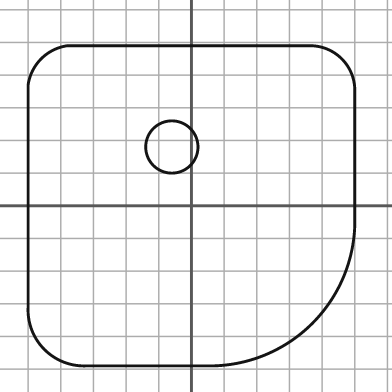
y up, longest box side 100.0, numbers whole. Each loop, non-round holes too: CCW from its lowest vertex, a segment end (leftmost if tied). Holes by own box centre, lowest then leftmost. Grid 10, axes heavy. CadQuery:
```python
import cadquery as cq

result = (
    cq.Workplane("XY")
    .moveTo(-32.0, -49.0)
    .lineTo(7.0, -49.0)
    .threePointArc((37.0, -36.0), (50.0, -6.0))
    .lineTo(50.0, 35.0)
    .threePointArc((46.0, 45.0), (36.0, 49.0))
    .lineTo(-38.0, 49.0)
    .threePointArc((-46.0, 45.0), (-50.0, 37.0))
    .lineTo(-50.0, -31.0)
    .threePointArc((-45.0, -44.0), (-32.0, -49.0))
    .close()
    .moveTo(-6.0, 18.0)
    .circle(8.0)
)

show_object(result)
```